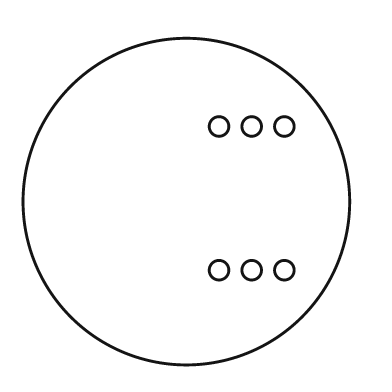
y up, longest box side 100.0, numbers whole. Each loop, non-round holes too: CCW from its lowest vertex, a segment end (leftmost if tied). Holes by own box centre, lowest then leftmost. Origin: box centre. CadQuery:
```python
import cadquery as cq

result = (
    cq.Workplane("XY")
    .moveTo(0.0, 0.0)
    .circle(50.0)
    .moveTo(10.0, -21.0)
    .circle(3.0)
    .moveTo(20.0, -21.0)
    .circle(3.0)
    .moveTo(30.0, -21.0)
    .circle(3.0)
    .moveTo(10.0, 23.0)
    .circle(3.0)
    .moveTo(20.0, 23.0)
    .circle(3.0)
    .moveTo(30.0, 23.0)
    .circle(3.0)
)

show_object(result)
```